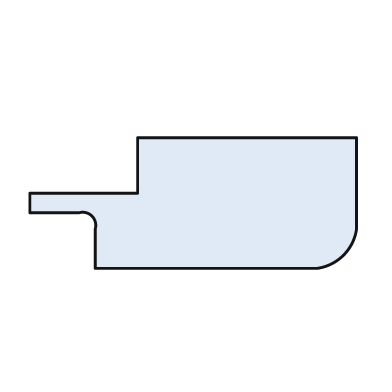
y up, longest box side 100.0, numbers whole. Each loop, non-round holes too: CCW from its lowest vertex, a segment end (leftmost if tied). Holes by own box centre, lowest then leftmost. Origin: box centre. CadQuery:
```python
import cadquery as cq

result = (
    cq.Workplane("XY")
    .moveTo(-30.0, -20.0)
    .lineTo(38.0, -20.0)
    .threePointArc((46.0, -16.0), (50.0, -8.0))
    .lineTo(50.0, 20.0)
    .lineTo(-17.0, 20.0)
    .lineTo(-17.0, 3.0)
    .lineTo(-50.0, 3.0)
    .lineTo(-50.0, -3.0)
    .lineTo(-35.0, -3.0)
    .threePointArc((-31.0, -4.0), (-30.0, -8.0))
    .close()
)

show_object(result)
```